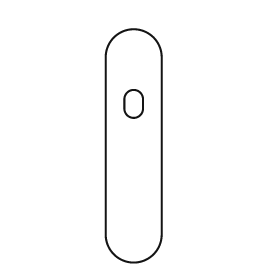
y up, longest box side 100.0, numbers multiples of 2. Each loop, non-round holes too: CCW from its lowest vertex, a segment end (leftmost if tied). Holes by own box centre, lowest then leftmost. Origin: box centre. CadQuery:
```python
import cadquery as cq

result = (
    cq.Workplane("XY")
    .moveTo(-12.0, -38.0)
    .threePointArc((0.0, -50.0), (12.0, -38.0))
    .lineTo(12.0, 38.0)
    .threePointArc((0.0, 50.0), (-12.0, 38.0))
    .close()
    .moveTo(-4.0, 16.0)
    .threePointArc((0.0, 12.0), (4.0, 16.0))
    .lineTo(4.0, 20.0)
    .threePointArc((0.0, 24.0), (-4.0, 20.0))
    .close()
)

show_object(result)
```